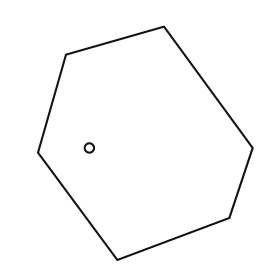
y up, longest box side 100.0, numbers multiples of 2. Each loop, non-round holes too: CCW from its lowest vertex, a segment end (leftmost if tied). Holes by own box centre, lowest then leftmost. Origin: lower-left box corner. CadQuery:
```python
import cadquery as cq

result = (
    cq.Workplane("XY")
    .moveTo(34.0, 0.0)
    .lineTo(82.0, 18.0)
    .lineTo(92.0, 48.0)
    .lineTo(54.0, 100.0)
    .lineTo(12.0, 88.0)
    .lineTo(0.0, 46.0)
    .close()
    .moveTo(22.0, 48.0)
    .circle(2.0)
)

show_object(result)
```